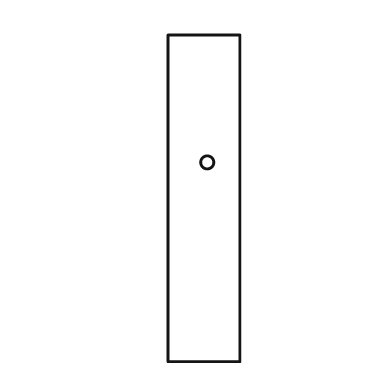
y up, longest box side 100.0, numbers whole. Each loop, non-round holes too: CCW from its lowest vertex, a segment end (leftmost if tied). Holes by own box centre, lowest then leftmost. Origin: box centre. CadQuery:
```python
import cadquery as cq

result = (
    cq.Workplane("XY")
    .moveTo(-11.0, -50.0)
    .lineTo(11.0, -50.0)
    .lineTo(11.0, 50.0)
    .lineTo(-11.0, 50.0)
    .close()
    .moveTo(1.0, 11.0)
    .circle(2.0)
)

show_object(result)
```